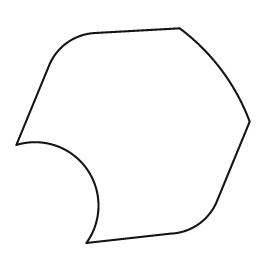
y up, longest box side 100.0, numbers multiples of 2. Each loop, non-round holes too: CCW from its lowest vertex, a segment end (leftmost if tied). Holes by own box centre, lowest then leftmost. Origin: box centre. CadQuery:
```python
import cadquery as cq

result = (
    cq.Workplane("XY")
    .moveTo(-20.0, -46.0)
    .lineTo(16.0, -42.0)
    .threePointArc((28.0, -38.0), (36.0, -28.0))
    .lineTo(50.0, 6.0)
    .threePointArc((38.0, 28.0), (20.0, 46.0))
    .lineTo(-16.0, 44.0)
    .threePointArc((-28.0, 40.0), (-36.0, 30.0))
    .lineTo(-50.0, -4.0)
    .threePointArc((-20.0, -14.0), (-20.0, -46.0))
    .close()
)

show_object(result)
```